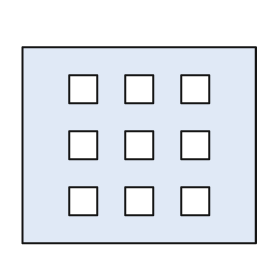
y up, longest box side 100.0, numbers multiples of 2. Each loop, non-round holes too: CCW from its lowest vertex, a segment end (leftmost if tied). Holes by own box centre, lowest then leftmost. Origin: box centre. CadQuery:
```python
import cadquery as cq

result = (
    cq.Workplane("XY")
    .moveTo(-50.0, -42.0)
    .lineTo(50.0, -42.0)
    .lineTo(50.0, 42.0)
    .lineTo(-50.0, 42.0)
    .close()
    .moveTo(-30.0, -30.0)
    .lineTo(-18.0, -30.0)
    .lineTo(-18.0, -18.0)
    .lineTo(-30.0, -18.0)
    .close()
    .moveTo(-6.0, -30.0)
    .lineTo(6.0, -30.0)
    .lineTo(6.0, -18.0)
    .lineTo(-6.0, -18.0)
    .close()
    .moveTo(18.0, -30.0)
    .lineTo(30.0, -30.0)
    .lineTo(30.0, -18.0)
    .lineTo(18.0, -18.0)
    .close()
    .moveTo(-30.0, -6.0)
    .lineTo(-18.0, -6.0)
    .lineTo(-18.0, 6.0)
    .lineTo(-30.0, 6.0)
    .close()
    .moveTo(-6.0, -6.0)
    .lineTo(6.0, -6.0)
    .lineTo(6.0, 6.0)
    .lineTo(-6.0, 6.0)
    .close()
    .moveTo(18.0, -6.0)
    .lineTo(30.0, -6.0)
    .lineTo(30.0, 6.0)
    .lineTo(18.0, 6.0)
    .close()
    .moveTo(-30.0, 18.0)
    .lineTo(-18.0, 18.0)
    .lineTo(-18.0, 30.0)
    .lineTo(-30.0, 30.0)
    .close()
    .moveTo(-6.0, 18.0)
    .lineTo(6.0, 18.0)
    .lineTo(6.0, 30.0)
    .lineTo(-6.0, 30.0)
    .close()
    .moveTo(18.0, 18.0)
    .lineTo(30.0, 18.0)
    .lineTo(30.0, 30.0)
    .lineTo(18.0, 30.0)
    .close()
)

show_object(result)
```